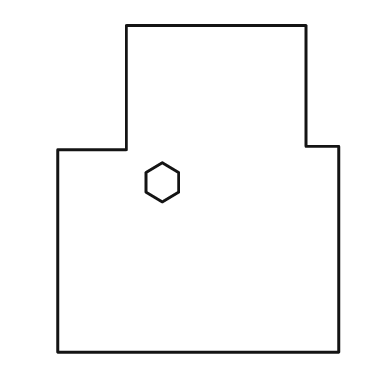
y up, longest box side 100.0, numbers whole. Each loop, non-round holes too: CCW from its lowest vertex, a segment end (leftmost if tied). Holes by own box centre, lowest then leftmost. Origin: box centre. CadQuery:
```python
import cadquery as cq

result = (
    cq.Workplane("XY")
    .moveTo(-43.0, -50.0)
    .lineTo(43.0, -50.0)
    .lineTo(43.0, 13.0)
    .lineTo(33.0, 13.0)
    .lineTo(33.0, 50.0)
    .lineTo(-22.0, 50.0)
    .lineTo(-22.0, 12.0)
    .lineTo(-43.0, 12.0)
    .close()
    .moveTo(-11.0, -4.0)
    .lineTo(-6.0, -1.0)
    .lineTo(-6.0, 5.0)
    .lineTo(-11.0, 8.0)
    .lineTo(-16.0, 5.0)
    .lineTo(-16.0, -1.0)
    .close()
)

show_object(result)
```